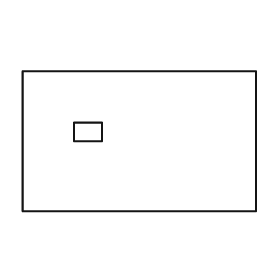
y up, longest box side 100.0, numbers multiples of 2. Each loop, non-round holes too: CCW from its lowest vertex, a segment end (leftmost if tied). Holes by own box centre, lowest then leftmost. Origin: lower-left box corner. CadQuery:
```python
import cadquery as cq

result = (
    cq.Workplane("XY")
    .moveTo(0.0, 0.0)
    .lineTo(100.0, 0.0)
    .lineTo(100.0, 60.0)
    .lineTo(0.0, 60.0)
    .close()
    .moveTo(22.0, 30.0)
    .lineTo(34.0, 30.0)
    .lineTo(34.0, 38.0)
    .lineTo(22.0, 38.0)
    .close()
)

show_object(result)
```